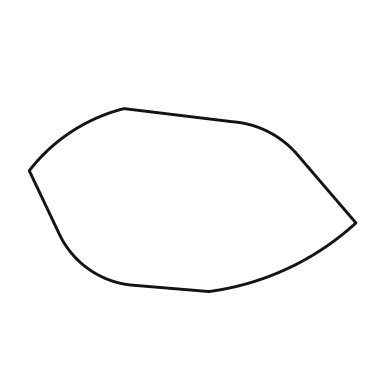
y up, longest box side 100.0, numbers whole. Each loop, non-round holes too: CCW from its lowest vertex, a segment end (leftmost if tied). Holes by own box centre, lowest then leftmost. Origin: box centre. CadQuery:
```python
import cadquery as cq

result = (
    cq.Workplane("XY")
    .moveTo(5.0, -28.0)
    .threePointArc((29.0, -21.0), (50.0, -7.0))
    .lineTo(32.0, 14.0)
    .threePointArc((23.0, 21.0), (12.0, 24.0))
    .lineTo(-21.0, 28.0)
    .threePointArc((-37.0, 21.0), (-50.0, 9.0))
    .lineTo(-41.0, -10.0)
    .threePointArc((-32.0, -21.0), (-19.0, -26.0))
    .close()
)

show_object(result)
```